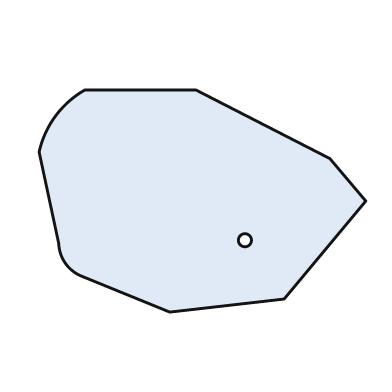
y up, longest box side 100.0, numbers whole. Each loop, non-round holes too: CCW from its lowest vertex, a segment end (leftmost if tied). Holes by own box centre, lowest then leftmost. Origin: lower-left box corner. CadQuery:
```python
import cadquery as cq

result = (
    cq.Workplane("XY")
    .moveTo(40.0, 0.0)
    .lineTo(75.0, 4.0)
    .lineTo(100.0, 34.0)
    .lineTo(89.0, 47.0)
    .lineTo(48.0, 68.0)
    .lineTo(14.0, 68.0)
    .threePointArc((5.0, 60.0), (0.0, 49.0))
    .lineTo(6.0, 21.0)
    .threePointArc((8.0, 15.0), (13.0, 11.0))
    .close()
    .moveTo(63.0, 22.0)
    .circle(2.0)
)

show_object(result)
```